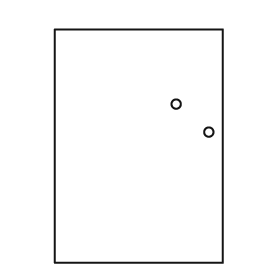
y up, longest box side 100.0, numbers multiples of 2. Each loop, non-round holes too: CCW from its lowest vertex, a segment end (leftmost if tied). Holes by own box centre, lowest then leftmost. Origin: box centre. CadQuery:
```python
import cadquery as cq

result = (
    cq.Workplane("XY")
    .moveTo(-36.0, -50.0)
    .lineTo(36.0, -50.0)
    .lineTo(36.0, 50.0)
    .lineTo(-36.0, 50.0)
    .close()
    .moveTo(30.0, 6.0)
    .circle(2.0)
    .moveTo(16.0, 18.0)
    .circle(2.0)
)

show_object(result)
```